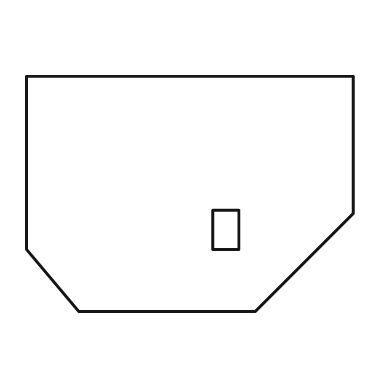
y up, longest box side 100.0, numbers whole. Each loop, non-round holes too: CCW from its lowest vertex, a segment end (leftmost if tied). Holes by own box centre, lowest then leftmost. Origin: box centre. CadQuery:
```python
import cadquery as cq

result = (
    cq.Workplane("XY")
    .moveTo(-34.0, -36.0)
    .lineTo(20.0, -36.0)
    .lineTo(50.0, -6.0)
    .lineTo(50.0, 36.0)
    .lineTo(-50.0, 36.0)
    .lineTo(-50.0, -17.0)
    .close()
    .moveTo(7.0, -17.0)
    .lineTo(15.0, -17.0)
    .lineTo(15.0, -5.0)
    .lineTo(7.0, -5.0)
    .close()
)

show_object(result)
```